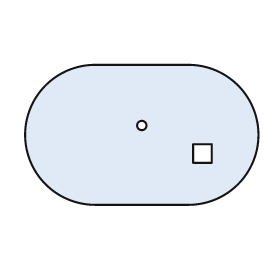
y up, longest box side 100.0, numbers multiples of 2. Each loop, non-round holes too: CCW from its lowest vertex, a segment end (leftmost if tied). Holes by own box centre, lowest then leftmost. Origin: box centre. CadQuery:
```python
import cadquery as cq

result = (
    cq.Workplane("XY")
    .moveTo(-20.0, -30.0)
    .lineTo(20.0, -30.0)
    .threePointArc((50.0, 0.0), (20.0, 30.0))
    .lineTo(-20.0, 30.0)
    .threePointArc((-50.0, 0.0), (-20.0, -30.0))
    .close()
    .moveTo(22.0, -12.0)
    .lineTo(30.0, -12.0)
    .lineTo(30.0, -4.0)
    .lineTo(22.0, -4.0)
    .close()
    .moveTo(0.0, 4.0)
    .circle(2.0)
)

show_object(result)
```